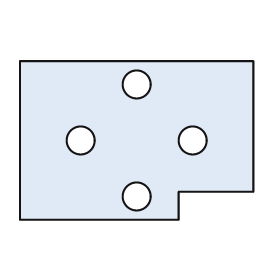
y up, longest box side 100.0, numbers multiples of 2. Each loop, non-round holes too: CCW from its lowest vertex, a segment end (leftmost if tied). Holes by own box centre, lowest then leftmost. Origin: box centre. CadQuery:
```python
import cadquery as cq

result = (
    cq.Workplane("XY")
    .moveTo(-50.0, -34.0)
    .lineTo(18.0, -34.0)
    .lineTo(18.0, -22.0)
    .lineTo(50.0, -22.0)
    .lineTo(50.0, 34.0)
    .lineTo(-50.0, 34.0)
    .close()
    .moveTo(0.0, -24.0)
    .circle(6.0)
    .moveTo(-24.0, 0.0)
    .circle(6.0)
    .moveTo(24.0, 0.0)
    .circle(6.0)
    .moveTo(0.0, 24.0)
    .circle(6.0)
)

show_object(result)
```